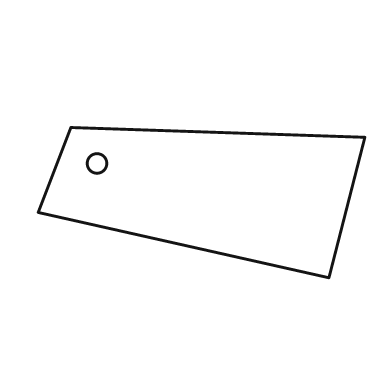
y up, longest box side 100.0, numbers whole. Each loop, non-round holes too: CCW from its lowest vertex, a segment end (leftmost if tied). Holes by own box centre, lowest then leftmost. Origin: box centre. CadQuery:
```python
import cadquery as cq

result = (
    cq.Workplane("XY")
    .moveTo(39.0, -23.0)
    .lineTo(50.0, 20.0)
    .lineTo(-40.0, 23.0)
    .lineTo(-50.0, -3.0)
    .close()
    .moveTo(-32.0, 12.0)
    .circle(3.0)
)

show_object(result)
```